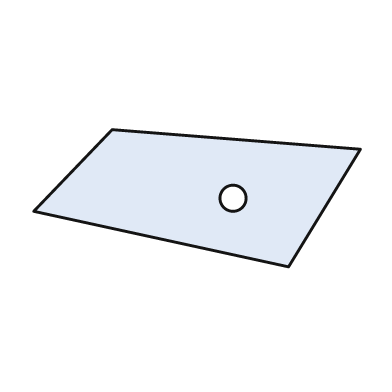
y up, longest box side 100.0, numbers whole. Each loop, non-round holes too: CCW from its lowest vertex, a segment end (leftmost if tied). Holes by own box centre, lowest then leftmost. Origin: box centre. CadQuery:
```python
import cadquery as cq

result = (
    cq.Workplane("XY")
    .moveTo(28.0, -21.0)
    .lineTo(50.0, 15.0)
    .lineTo(-26.0, 21.0)
    .lineTo(-50.0, -4.0)
    .close()
    .moveTo(11.0, 0.0)
    .circle(4.0)
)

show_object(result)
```